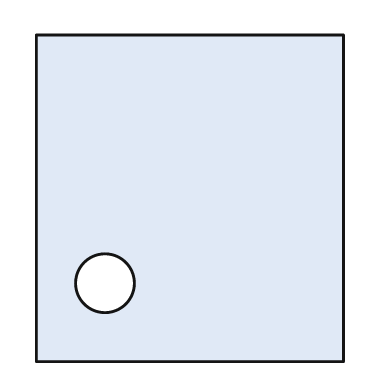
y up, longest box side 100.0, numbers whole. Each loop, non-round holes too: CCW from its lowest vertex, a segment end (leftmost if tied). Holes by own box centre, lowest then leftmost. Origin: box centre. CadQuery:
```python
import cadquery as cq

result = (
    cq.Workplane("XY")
    .moveTo(-47.0, -50.0)
    .lineTo(47.0, -50.0)
    .lineTo(47.0, 50.0)
    .lineTo(-47.0, 50.0)
    .close()
    .moveTo(-26.0, -26.0)
    .circle(9.0)
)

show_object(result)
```